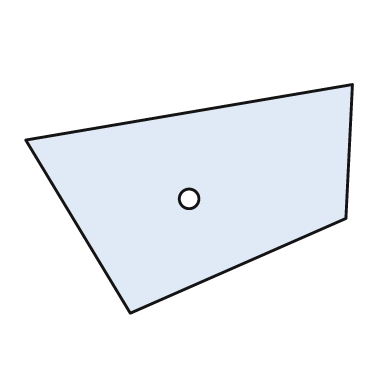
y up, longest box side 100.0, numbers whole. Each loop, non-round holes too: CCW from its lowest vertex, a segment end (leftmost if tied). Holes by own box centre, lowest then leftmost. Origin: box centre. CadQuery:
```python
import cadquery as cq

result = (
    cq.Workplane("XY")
    .moveTo(-18.0, -35.0)
    .lineTo(48.0, -6.0)
    .lineTo(50.0, 35.0)
    .lineTo(-50.0, 18.0)
    .close()
    .moveTo(0.0, 0.0)
    .circle(3.0)
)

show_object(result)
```